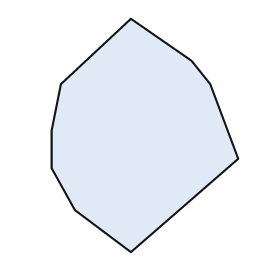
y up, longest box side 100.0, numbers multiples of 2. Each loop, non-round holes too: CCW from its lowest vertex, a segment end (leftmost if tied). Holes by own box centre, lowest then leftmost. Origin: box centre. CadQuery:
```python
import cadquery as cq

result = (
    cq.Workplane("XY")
    .moveTo(-6.0, -50.0)
    .lineTo(40.0, -10.0)
    .lineTo(28.0, 22.0)
    .lineTo(20.0, 32.0)
    .lineTo(-6.0, 50.0)
    .lineTo(-36.0, 22.0)
    .lineTo(-40.0, 2.0)
    .lineTo(-40.0, -14.0)
    .lineTo(-30.0, -32.0)
    .close()
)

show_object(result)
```